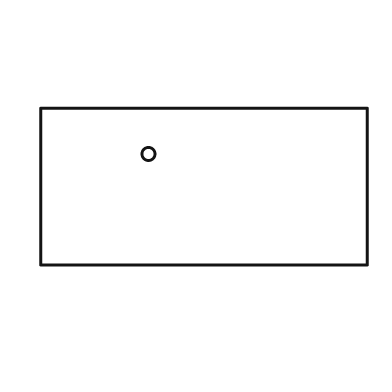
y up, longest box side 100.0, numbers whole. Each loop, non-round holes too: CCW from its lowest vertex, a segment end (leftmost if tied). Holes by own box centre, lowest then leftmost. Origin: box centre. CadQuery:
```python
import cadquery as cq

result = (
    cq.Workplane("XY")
    .moveTo(-50.0, -24.0)
    .lineTo(50.0, -24.0)
    .lineTo(50.0, 24.0)
    .lineTo(-50.0, 24.0)
    .close()
    .moveTo(-17.0, 10.0)
    .circle(2.0)
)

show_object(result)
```